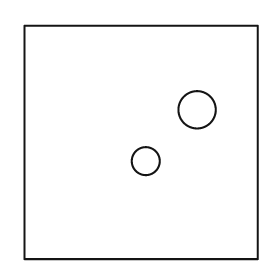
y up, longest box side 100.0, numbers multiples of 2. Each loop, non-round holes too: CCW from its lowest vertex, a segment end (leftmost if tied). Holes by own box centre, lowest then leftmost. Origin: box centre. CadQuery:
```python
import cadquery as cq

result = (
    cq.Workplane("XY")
    .moveTo(-50.0, -50.0)
    .lineTo(50.0, -50.0)
    .lineTo(50.0, 50.0)
    .lineTo(-50.0, 50.0)
    .close()
    .moveTo(2.0, -8.0)
    .circle(6.0)
    .moveTo(24.0, 14.0)
    .circle(8.0)
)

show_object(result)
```